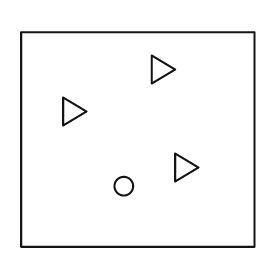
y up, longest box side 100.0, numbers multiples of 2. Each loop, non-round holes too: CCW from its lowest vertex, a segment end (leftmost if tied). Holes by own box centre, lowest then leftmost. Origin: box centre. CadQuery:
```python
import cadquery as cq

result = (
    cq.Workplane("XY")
    .moveTo(-50.0, -46.0)
    .lineTo(50.0, -46.0)
    .lineTo(50.0, 46.0)
    .lineTo(-50.0, 46.0)
    .close()
    .moveTo(-6.0, -20.0)
    .circle(4.0)
    .moveTo(16.0, -18.0)
    .lineTo(26.0, -12.0)
    .lineTo(16.0, -6.0)
    .close()
    .moveTo(-32.0, 6.0)
    .lineTo(-22.0, 12.0)
    .lineTo(-32.0, 18.0)
    .close()
    .moveTo(6.0, 24.0)
    .lineTo(16.0, 30.0)
    .lineTo(6.0, 36.0)
    .close()
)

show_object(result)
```